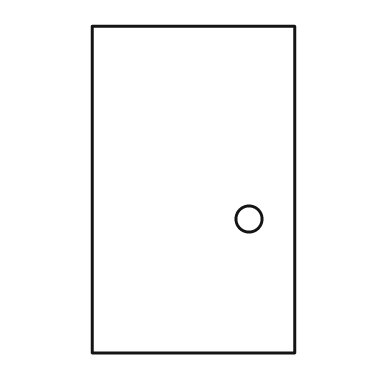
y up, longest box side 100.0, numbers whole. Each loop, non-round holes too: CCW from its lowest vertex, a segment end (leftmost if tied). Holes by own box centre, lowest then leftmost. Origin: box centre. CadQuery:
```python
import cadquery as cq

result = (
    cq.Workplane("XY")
    .moveTo(-31.0, -50.0)
    .lineTo(31.0, -50.0)
    .lineTo(31.0, 50.0)
    .lineTo(-31.0, 50.0)
    .close()
    .moveTo(17.0, -9.0)
    .circle(4.0)
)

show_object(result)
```